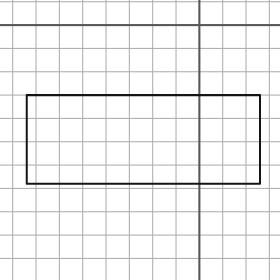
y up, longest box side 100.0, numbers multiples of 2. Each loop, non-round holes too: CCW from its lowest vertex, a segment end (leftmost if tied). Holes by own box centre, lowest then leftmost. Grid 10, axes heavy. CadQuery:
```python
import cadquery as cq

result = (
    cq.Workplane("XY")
    .moveTo(-74.0, -68.0)
    .lineTo(26.0, -68.0)
    .lineTo(26.0, -30.0)
    .lineTo(-74.0, -30.0)
    .close()
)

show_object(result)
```